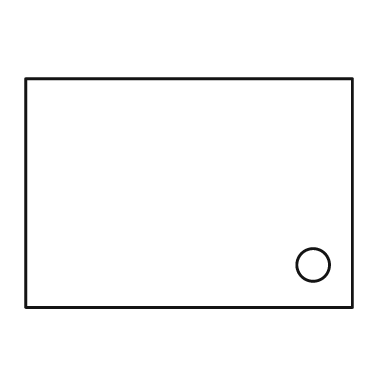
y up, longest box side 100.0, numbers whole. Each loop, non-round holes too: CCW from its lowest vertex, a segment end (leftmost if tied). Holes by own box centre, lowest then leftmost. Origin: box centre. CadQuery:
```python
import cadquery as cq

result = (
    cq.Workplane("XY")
    .moveTo(-50.0, -35.0)
    .lineTo(50.0, -35.0)
    .lineTo(50.0, 35.0)
    .lineTo(-50.0, 35.0)
    .close()
    .moveTo(38.0, -22.0)
    .circle(5.0)
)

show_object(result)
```